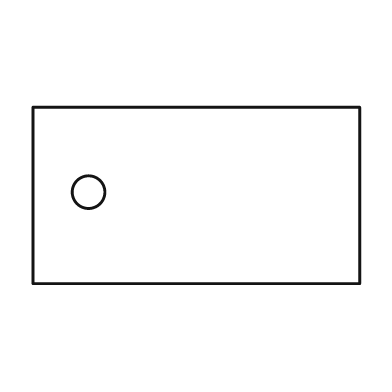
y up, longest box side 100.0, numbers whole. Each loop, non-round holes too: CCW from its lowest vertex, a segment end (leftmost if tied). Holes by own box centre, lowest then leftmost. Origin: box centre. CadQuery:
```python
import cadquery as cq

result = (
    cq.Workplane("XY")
    .moveTo(-50.0, -27.0)
    .lineTo(50.0, -27.0)
    .lineTo(50.0, 27.0)
    .lineTo(-50.0, 27.0)
    .close()
    .moveTo(-33.0, 1.0)
    .circle(5.0)
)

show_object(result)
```